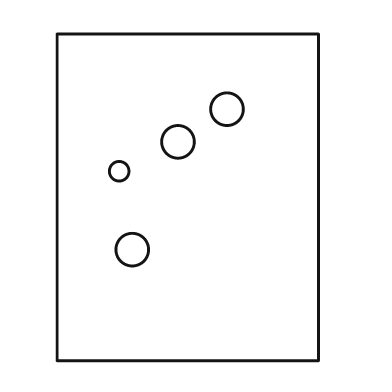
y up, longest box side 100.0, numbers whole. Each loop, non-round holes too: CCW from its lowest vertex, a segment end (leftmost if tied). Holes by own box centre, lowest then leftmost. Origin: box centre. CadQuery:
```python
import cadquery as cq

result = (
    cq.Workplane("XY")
    .moveTo(-40.0, -50.0)
    .lineTo(40.0, -50.0)
    .lineTo(40.0, 50.0)
    .lineTo(-40.0, 50.0)
    .close()
    .moveTo(-17.0, -16.0)
    .circle(5.0)
    .moveTo(-21.0, 8.0)
    .circle(3.0)
    .moveTo(-3.0, 17.0)
    .circle(5.0)
    .moveTo(12.0, 27.0)
    .circle(5.0)
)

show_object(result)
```